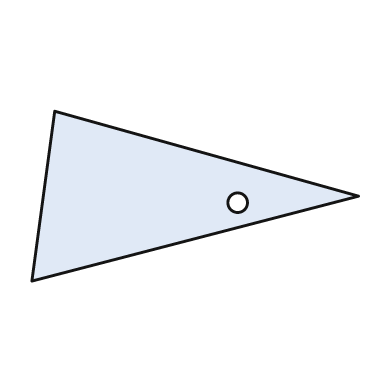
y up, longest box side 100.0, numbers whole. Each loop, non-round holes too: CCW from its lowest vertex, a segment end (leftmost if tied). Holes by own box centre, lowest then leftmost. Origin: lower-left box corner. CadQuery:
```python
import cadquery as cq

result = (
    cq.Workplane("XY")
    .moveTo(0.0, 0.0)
    .lineTo(100.0, 26.0)
    .lineTo(7.0, 52.0)
    .close()
    .moveTo(63.0, 24.0)
    .circle(3.0)
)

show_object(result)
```